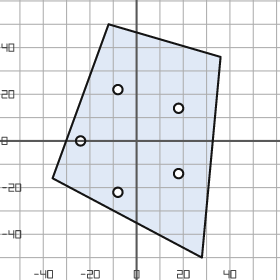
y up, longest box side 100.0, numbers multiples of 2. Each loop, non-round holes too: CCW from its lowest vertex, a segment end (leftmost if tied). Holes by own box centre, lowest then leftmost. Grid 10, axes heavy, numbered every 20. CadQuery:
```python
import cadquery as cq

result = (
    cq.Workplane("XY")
    .moveTo(28.0, -50.0)
    .lineTo(36.0, 36.0)
    .lineTo(-12.0, 50.0)
    .lineTo(-36.0, -16.0)
    .close()
    .moveTo(-8.0, -22.0)
    .circle(2.0)
    .moveTo(18.0, -14.0)
    .circle(2.0)
    .moveTo(-24.0, 0.0)
    .circle(2.0)
    .moveTo(18.0, 14.0)
    .circle(2.0)
    .moveTo(-8.0, 22.0)
    .circle(2.0)
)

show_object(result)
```